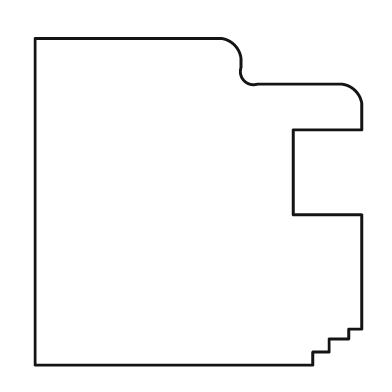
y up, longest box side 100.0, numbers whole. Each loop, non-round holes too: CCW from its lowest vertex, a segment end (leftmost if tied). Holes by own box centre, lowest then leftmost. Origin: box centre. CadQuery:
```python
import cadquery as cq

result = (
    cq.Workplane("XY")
    .moveTo(-50.0, -50.0)
    .lineTo(35.0, -50.0)
    .lineTo(35.0, -46.0)
    .lineTo(40.0, -46.0)
    .lineTo(40.0, -42.0)
    .lineTo(46.0, -42.0)
    .lineTo(46.0, -39.0)
    .lineTo(50.0, -39.0)
    .lineTo(50.0, -4.0)
    .lineTo(29.0, -4.0)
    .lineTo(29.0, 22.0)
    .lineTo(50.0, 22.0)
    .lineTo(50.0, 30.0)
    .threePointArc((48.0, 34.0), (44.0, 36.0))
    .lineTo(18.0, 36.0)
    .threePointArc((14.0, 37.0), (13.0, 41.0))
    .lineTo(13.0, 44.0)
    .threePointArc((11.0, 48.0), (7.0, 50.0))
    .lineTo(-50.0, 50.0)
    .close()
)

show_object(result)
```